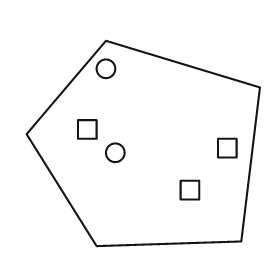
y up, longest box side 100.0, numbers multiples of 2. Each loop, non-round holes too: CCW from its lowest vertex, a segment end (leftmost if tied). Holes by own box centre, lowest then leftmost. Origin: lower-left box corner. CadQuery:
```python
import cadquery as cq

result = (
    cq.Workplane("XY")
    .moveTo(30.0, 0.0)
    .lineTo(92.0, 2.0)
    .lineTo(100.0, 68.0)
    .lineTo(34.0, 88.0)
    .lineTo(0.0, 48.0)
    .close()
    .moveTo(66.0, 20.0)
    .lineTo(74.0, 20.0)
    .lineTo(74.0, 28.0)
    .lineTo(66.0, 28.0)
    .close()
    .moveTo(38.0, 40.0)
    .circle(4.0)
    .moveTo(82.0, 38.0)
    .lineTo(90.0, 38.0)
    .lineTo(90.0, 46.0)
    .lineTo(82.0, 46.0)
    .close()
    .moveTo(22.0, 46.0)
    .lineTo(30.0, 46.0)
    .lineTo(30.0, 54.0)
    .lineTo(22.0, 54.0)
    .close()
    .moveTo(34.0, 76.0)
    .circle(4.0)
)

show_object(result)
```